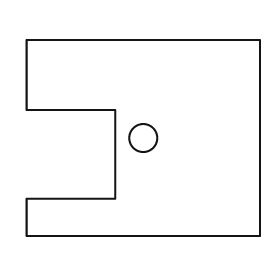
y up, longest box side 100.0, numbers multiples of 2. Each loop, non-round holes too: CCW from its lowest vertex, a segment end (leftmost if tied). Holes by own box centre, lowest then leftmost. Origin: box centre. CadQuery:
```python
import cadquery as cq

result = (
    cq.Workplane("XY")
    .moveTo(-50.0, -42.0)
    .lineTo(50.0, -42.0)
    .lineTo(50.0, 42.0)
    .lineTo(-50.0, 42.0)
    .lineTo(-50.0, 12.0)
    .lineTo(-12.0, 12.0)
    .lineTo(-12.0, -26.0)
    .lineTo(-50.0, -26.0)
    .close()
    .moveTo(0.0, 0.0)
    .circle(6.0)
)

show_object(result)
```